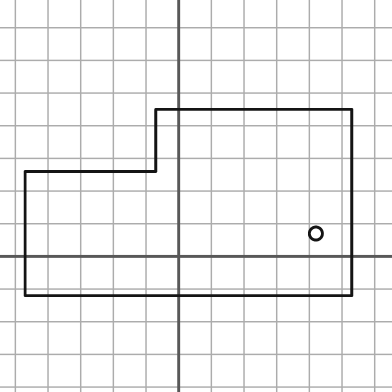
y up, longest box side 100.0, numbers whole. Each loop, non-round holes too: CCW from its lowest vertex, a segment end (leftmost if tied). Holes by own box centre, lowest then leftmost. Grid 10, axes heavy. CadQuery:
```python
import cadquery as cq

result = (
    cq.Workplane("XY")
    .moveTo(-47.0, -12.0)
    .lineTo(53.0, -12.0)
    .lineTo(53.0, 45.0)
    .lineTo(-7.0, 45.0)
    .lineTo(-7.0, 26.0)
    .lineTo(-47.0, 26.0)
    .close()
    .moveTo(42.0, 7.0)
    .circle(2.0)
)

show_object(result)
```